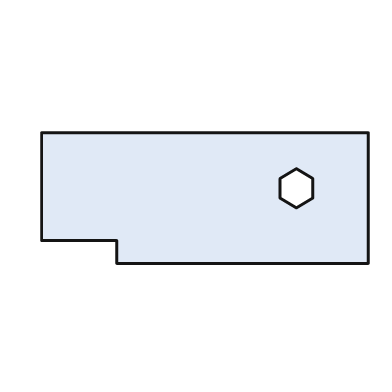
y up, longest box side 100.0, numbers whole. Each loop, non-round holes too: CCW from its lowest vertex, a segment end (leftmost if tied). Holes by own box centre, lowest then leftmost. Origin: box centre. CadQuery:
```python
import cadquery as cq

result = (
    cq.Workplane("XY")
    .moveTo(-27.0, -20.0)
    .lineTo(50.0, -20.0)
    .lineTo(50.0, 20.0)
    .lineTo(-50.0, 20.0)
    .lineTo(-50.0, -13.0)
    .lineTo(-27.0, -13.0)
    .close()
    .moveTo(28.0, -3.0)
    .lineTo(33.0, 0.0)
    .lineTo(33.0, 6.0)
    .lineTo(28.0, 9.0)
    .lineTo(23.0, 6.0)
    .lineTo(23.0, 0.0)
    .close()
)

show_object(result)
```